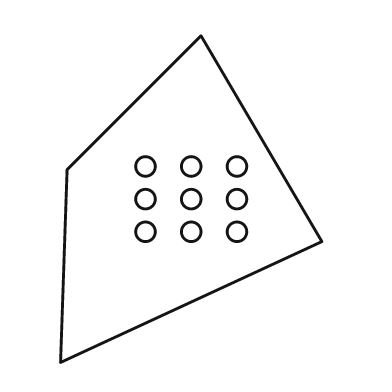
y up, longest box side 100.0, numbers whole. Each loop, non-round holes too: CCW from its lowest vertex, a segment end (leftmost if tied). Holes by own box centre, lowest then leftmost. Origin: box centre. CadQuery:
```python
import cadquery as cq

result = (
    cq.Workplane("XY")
    .moveTo(-40.0, -50.0)
    .lineTo(40.0, -13.0)
    .lineTo(3.0, 50.0)
    .lineTo(-38.0, 9.0)
    .close()
    .moveTo(-14.0, -10.0)
    .circle(3.0)
    .moveTo(0.0, -10.0)
    .circle(3.0)
    .moveTo(14.0, -10.0)
    .circle(3.0)
    .moveTo(-14.0, 0.0)
    .circle(3.0)
    .moveTo(0.0, 0.0)
    .circle(3.0)
    .moveTo(14.0, 0.0)
    .circle(3.0)
    .moveTo(-14.0, 10.0)
    .circle(3.0)
    .moveTo(0.0, 10.0)
    .circle(3.0)
    .moveTo(14.0, 10.0)
    .circle(3.0)
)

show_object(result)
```